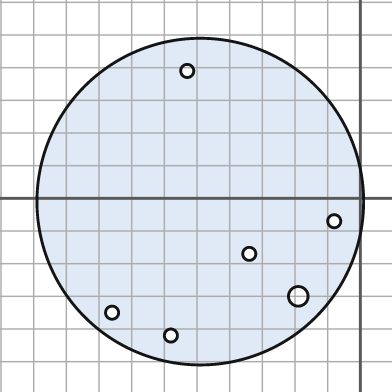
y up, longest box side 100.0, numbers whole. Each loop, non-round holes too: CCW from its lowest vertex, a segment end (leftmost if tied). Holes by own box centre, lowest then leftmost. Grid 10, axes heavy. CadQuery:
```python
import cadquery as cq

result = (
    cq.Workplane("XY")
    .moveTo(-49.0, -1.0)
    .circle(50.0)
    .moveTo(-58.0, -42.0)
    .circle(2.0)
    .moveTo(-76.0, -35.0)
    .circle(2.0)
    .moveTo(-19.0, -30.0)
    .circle(3.0)
    .moveTo(-34.0, -17.0)
    .circle(2.0)
    .moveTo(-8.0, -7.0)
    .circle(2.0)
    .moveTo(-53.0, 39.0)
    .circle(2.0)
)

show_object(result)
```